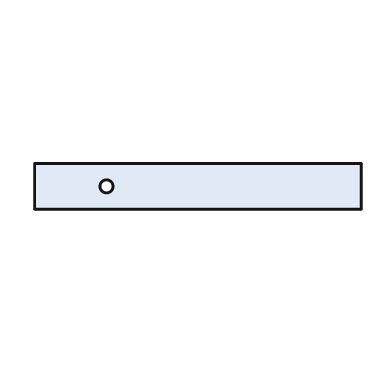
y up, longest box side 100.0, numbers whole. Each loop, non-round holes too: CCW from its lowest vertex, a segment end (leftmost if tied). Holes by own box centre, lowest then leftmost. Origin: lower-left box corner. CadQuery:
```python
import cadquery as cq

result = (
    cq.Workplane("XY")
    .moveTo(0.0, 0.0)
    .lineTo(100.0, 0.0)
    .lineTo(100.0, 14.0)
    .lineTo(0.0, 14.0)
    .close()
    .moveTo(22.0, 7.0)
    .circle(2.0)
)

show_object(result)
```